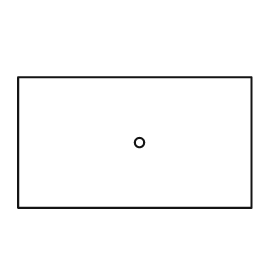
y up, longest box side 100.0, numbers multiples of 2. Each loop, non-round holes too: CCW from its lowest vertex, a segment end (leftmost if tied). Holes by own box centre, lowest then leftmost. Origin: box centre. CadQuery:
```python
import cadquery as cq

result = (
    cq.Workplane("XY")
    .moveTo(-50.0, -28.0)
    .lineTo(50.0, -28.0)
    .lineTo(50.0, 28.0)
    .lineTo(-50.0, 28.0)
    .close()
    .moveTo(2.0, 0.0)
    .circle(2.0)
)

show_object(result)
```